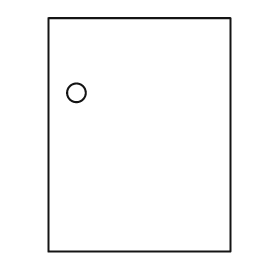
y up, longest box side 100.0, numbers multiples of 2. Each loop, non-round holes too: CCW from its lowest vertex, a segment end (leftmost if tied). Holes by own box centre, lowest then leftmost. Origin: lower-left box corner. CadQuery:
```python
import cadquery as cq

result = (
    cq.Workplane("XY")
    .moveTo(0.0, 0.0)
    .lineTo(78.0, 0.0)
    .lineTo(78.0, 100.0)
    .lineTo(0.0, 100.0)
    .close()
    .moveTo(12.0, 68.0)
    .circle(4.0)
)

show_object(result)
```